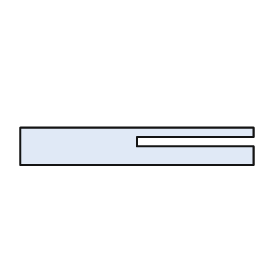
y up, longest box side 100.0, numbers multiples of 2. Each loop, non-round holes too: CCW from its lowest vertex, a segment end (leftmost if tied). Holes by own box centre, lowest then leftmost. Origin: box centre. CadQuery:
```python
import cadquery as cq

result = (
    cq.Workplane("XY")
    .moveTo(-50.0, -8.0)
    .lineTo(50.0, -8.0)
    .lineTo(50.0, 0.0)
    .lineTo(0.0, 0.0)
    .lineTo(0.0, 4.0)
    .lineTo(50.0, 4.0)
    .lineTo(50.0, 8.0)
    .lineTo(-50.0, 8.0)
    .close()
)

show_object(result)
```